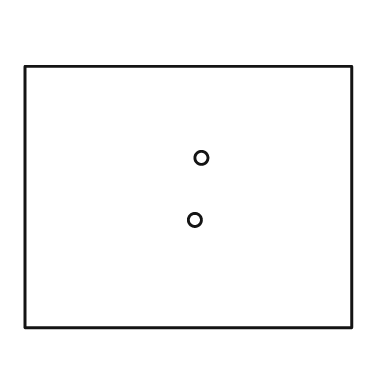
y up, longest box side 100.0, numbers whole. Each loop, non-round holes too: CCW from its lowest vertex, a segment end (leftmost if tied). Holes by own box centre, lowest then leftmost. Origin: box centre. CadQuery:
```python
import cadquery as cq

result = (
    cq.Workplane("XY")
    .moveTo(-50.0, -40.0)
    .lineTo(50.0, -40.0)
    .lineTo(50.0, 40.0)
    .lineTo(-50.0, 40.0)
    .close()
    .moveTo(2.0, -7.0)
    .circle(2.0)
    .moveTo(4.0, 12.0)
    .circle(2.0)
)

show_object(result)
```